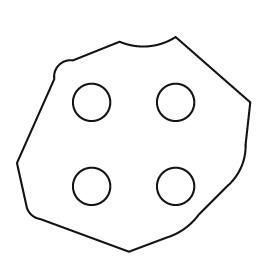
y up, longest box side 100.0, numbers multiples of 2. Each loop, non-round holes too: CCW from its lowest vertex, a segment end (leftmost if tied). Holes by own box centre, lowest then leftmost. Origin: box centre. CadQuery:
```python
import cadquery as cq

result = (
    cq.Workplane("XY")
    .moveTo(-2.0, -46.0)
    .lineTo(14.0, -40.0)
    .threePointArc((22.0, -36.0), (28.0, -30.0))
    .lineTo(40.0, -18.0)
    .threePointArc((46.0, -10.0), (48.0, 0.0))
    .lineTo(50.0, 18.0)
    .lineTo(18.0, 46.0)
    .threePointArc((6.0, 42.0), (-6.0, 44.0))
    .lineTo(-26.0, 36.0)
    .threePointArc((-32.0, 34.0), (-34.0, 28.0))
    .lineTo(-50.0, -8.0)
    .lineTo(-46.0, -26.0)
    .threePointArc((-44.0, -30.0), (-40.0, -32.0))
    .close()
    .moveTo(-18.0, -18.0)
    .circle(8.0)
    .moveTo(18.0, -18.0)
    .circle(8.0)
    .moveTo(-18.0, 18.0)
    .circle(8.0)
    .moveTo(18.0, 18.0)
    .circle(8.0)
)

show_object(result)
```